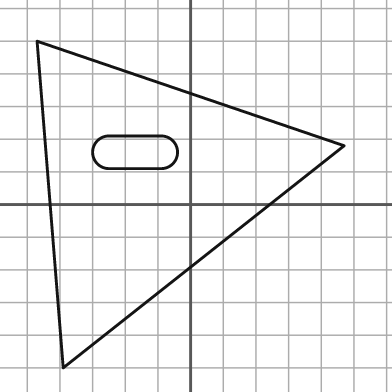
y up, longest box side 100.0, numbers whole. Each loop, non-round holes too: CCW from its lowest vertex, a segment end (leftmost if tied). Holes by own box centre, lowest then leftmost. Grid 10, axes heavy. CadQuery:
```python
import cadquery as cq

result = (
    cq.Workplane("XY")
    .moveTo(-39.0, -50.0)
    .lineTo(47.0, 18.0)
    .lineTo(-47.0, 50.0)
    .close()
    .moveTo(-25.0, 11.0)
    .lineTo(-9.0, 11.0)
    .threePointArc((-4.0, 16.0), (-9.0, 21.0))
    .lineTo(-25.0, 21.0)
    .threePointArc((-30.0, 16.0), (-25.0, 11.0))
    .close()
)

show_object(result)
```